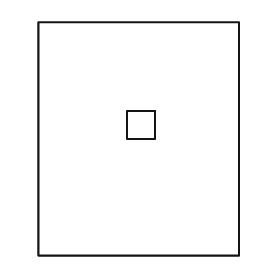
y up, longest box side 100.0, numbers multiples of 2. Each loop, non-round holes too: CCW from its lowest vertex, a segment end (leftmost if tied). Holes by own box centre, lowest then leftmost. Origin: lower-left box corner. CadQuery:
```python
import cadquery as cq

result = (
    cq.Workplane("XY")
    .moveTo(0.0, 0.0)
    .lineTo(86.0, 0.0)
    .lineTo(86.0, 100.0)
    .lineTo(0.0, 100.0)
    .close()
    .moveTo(38.0, 50.0)
    .lineTo(50.0, 50.0)
    .lineTo(50.0, 62.0)
    .lineTo(38.0, 62.0)
    .close()
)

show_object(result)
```